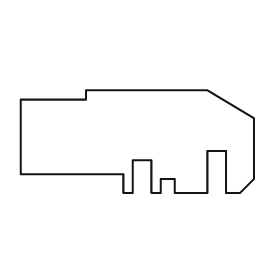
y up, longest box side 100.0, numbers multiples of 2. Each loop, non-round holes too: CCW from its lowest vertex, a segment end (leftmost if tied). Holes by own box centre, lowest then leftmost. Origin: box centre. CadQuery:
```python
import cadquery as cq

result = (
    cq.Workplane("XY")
    .moveTo(-6.0, -22.0)
    .lineTo(-2.0, -22.0)
    .lineTo(-2.0, -8.0)
    .lineTo(6.0, -8.0)
    .lineTo(6.0, -22.0)
    .lineTo(10.0, -22.0)
    .lineTo(10.0, -16.0)
    .lineTo(16.0, -16.0)
    .lineTo(16.0, -22.0)
    .lineTo(30.0, -22.0)
    .lineTo(30.0, -4.0)
    .lineTo(38.0, -4.0)
    .lineTo(38.0, -22.0)
    .lineTo(44.0, -22.0)
    .lineTo(50.0, -16.0)
    .lineTo(50.0, 10.0)
    .lineTo(30.0, 22.0)
    .lineTo(-22.0, 22.0)
    .lineTo(-22.0, 18.0)
    .lineTo(-50.0, 18.0)
    .lineTo(-50.0, -14.0)
    .lineTo(-6.0, -14.0)
    .close()
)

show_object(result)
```